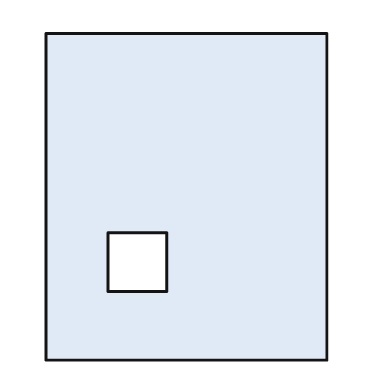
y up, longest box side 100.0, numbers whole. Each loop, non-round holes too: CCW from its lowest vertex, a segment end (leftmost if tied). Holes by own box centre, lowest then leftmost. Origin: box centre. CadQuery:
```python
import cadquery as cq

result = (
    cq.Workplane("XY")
    .moveTo(-43.0, -50.0)
    .lineTo(43.0, -50.0)
    .lineTo(43.0, 50.0)
    .lineTo(-43.0, 50.0)
    .close()
    .moveTo(-24.0, -29.0)
    .lineTo(-6.0, -29.0)
    .lineTo(-6.0, -11.0)
    .lineTo(-24.0, -11.0)
    .close()
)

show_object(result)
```